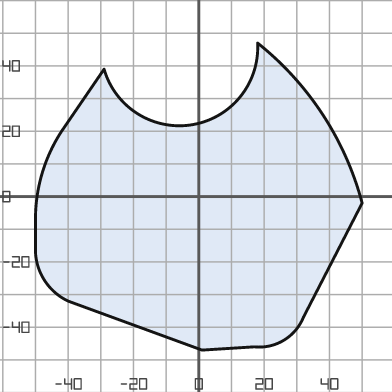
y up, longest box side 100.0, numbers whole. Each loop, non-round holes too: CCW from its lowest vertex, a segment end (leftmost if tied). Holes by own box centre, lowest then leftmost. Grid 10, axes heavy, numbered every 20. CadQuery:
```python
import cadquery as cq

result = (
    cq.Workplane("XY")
    .moveTo(1.0, -47.0)
    .lineTo(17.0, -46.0)
    .threePointArc((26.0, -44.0), (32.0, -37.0))
    .lineTo(50.0, -2.0)
    .threePointArc((38.0, 25.0), (18.0, 47.0))
    .threePointArc((-2.0, 22.0), (-29.0, 39.0))
    .lineTo(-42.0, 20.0)
    .threePointArc((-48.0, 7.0), (-50.0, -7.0))
    .lineTo(-50.0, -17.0)
    .threePointArc((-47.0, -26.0), (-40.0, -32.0))
    .close()
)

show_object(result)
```